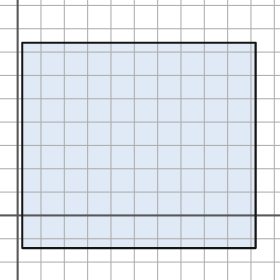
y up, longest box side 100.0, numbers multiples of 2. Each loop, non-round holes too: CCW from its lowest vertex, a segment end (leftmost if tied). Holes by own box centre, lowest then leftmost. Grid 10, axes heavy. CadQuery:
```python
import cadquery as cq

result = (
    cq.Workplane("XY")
    .moveTo(2.0, -14.0)
    .lineTo(102.0, -14.0)
    .lineTo(102.0, 74.0)
    .lineTo(2.0, 74.0)
    .close()
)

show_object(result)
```